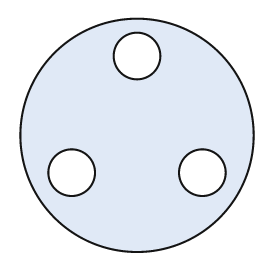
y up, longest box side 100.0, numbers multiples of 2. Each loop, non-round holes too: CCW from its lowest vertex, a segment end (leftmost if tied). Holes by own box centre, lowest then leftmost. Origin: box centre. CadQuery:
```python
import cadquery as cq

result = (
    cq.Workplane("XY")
    .moveTo(0.0, 0.0)
    .circle(50.0)
    .moveTo(-28.0, -16.0)
    .circle(10.0)
    .moveTo(28.0, -16.0)
    .circle(10.0)
    .moveTo(0.0, 34.0)
    .circle(10.0)
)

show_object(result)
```